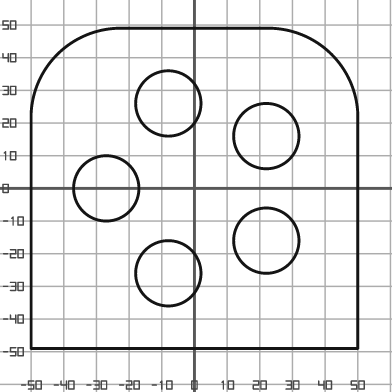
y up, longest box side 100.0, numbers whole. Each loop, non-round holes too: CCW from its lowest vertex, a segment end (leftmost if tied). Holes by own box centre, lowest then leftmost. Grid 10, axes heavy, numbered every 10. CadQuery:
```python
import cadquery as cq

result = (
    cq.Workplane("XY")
    .moveTo(-50.0, -49.0)
    .lineTo(50.0, -49.0)
    .lineTo(50.0, 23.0)
    .threePointArc((42.0, 41.0), (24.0, 49.0))
    .lineTo(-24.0, 49.0)
    .threePointArc((-42.0, 41.0), (-50.0, 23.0))
    .close()
    .moveTo(-8.0, -26.0)
    .circle(10.0)
    .moveTo(22.0, -16.0)
    .circle(10.0)
    .moveTo(-27.0, 0.0)
    .circle(10.0)
    .moveTo(22.0, 16.0)
    .circle(10.0)
    .moveTo(-8.0, 26.0)
    .circle(10.0)
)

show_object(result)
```